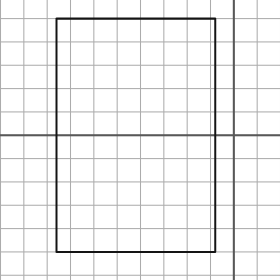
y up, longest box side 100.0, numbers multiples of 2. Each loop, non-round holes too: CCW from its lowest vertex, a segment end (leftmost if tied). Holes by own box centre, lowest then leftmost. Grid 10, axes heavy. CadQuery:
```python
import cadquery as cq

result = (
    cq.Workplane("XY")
    .moveTo(-76.0, -50.0)
    .lineTo(-8.0, -50.0)
    .lineTo(-8.0, 50.0)
    .lineTo(-76.0, 50.0)
    .close()
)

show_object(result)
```